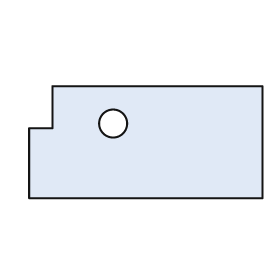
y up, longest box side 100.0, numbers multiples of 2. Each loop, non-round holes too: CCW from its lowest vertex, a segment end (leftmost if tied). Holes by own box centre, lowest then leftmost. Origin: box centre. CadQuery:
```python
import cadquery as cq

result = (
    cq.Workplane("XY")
    .moveTo(-50.0, -24.0)
    .lineTo(50.0, -24.0)
    .lineTo(50.0, 24.0)
    .lineTo(-40.0, 24.0)
    .lineTo(-40.0, 6.0)
    .lineTo(-50.0, 6.0)
    .close()
    .moveTo(-14.0, 8.0)
    .circle(6.0)
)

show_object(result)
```